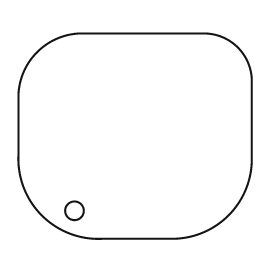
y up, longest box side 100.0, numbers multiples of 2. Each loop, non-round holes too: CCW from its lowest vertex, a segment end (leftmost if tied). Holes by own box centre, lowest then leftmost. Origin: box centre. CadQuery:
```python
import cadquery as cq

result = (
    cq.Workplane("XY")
    .moveTo(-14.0, -44.0)
    .lineTo(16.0, -44.0)
    .threePointArc((40.0, -34.0), (50.0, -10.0))
    .lineTo(50.0, 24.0)
    .threePointArc((44.0, 38.0), (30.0, 44.0))
    .lineTo(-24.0, 44.0)
    .threePointArc((-42.0, 36.0), (-50.0, 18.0))
    .lineTo(-50.0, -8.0)
    .threePointArc((-40.0, -34.0), (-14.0, -44.0))
    .close()
    .moveTo(-26.0, -32.0)
    .circle(4.0)
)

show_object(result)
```